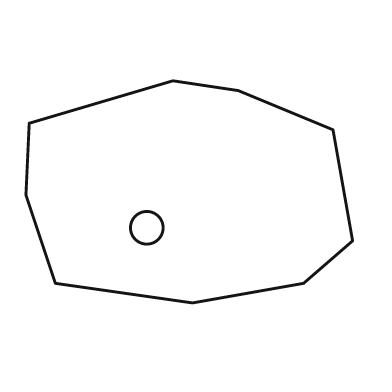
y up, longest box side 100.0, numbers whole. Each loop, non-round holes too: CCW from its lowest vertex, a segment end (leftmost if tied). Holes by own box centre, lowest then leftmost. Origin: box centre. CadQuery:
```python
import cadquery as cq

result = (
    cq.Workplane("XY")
    .moveTo(1.0, -34.0)
    .lineTo(35.0, -28.0)
    .lineTo(50.0, -15.0)
    .lineTo(44.0, 19.0)
    .lineTo(15.0, 31.0)
    .lineTo(-5.0, 34.0)
    .lineTo(-49.0, 21.0)
    .lineTo(-50.0, -1.0)
    .lineTo(-41.0, -28.0)
    .close()
    .moveTo(-13.0, -11.0)
    .circle(5.0)
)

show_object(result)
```